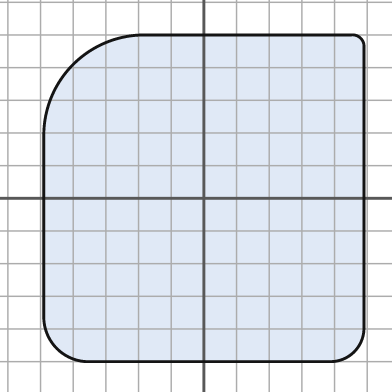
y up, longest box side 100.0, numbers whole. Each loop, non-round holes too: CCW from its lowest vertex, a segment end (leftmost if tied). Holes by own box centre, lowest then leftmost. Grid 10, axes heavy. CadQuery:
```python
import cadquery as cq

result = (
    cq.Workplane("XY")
    .moveTo(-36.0, -50.0)
    .lineTo(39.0, -50.0)
    .threePointArc((46.0, -47.0), (49.0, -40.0))
    .lineTo(49.0, 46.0)
    .threePointArc((48.0, 49.0), (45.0, 50.0))
    .lineTo(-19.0, 50.0)
    .threePointArc((-40.0, 41.0), (-49.0, 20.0))
    .lineTo(-49.0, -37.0)
    .threePointArc((-45.0, -46.0), (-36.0, -50.0))
    .close()
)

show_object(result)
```